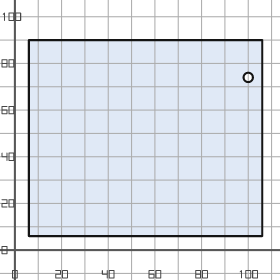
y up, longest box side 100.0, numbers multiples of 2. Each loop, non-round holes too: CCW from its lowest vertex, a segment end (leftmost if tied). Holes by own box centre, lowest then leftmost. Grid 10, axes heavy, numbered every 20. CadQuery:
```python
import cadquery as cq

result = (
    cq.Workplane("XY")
    .moveTo(6.0, 6.0)
    .lineTo(106.0, 6.0)
    .lineTo(106.0, 90.0)
    .lineTo(6.0, 90.0)
    .close()
    .moveTo(100.0, 74.0)
    .circle(2.0)
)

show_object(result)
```